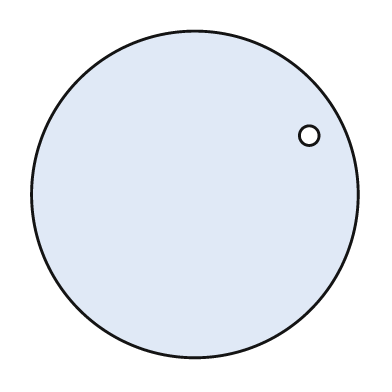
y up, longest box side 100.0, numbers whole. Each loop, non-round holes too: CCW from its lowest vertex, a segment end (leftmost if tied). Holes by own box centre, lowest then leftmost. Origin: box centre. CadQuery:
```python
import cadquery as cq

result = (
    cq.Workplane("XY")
    .moveTo(0.0, 0.0)
    .circle(50.0)
    .moveTo(35.0, 18.0)
    .circle(3.0)
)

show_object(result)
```